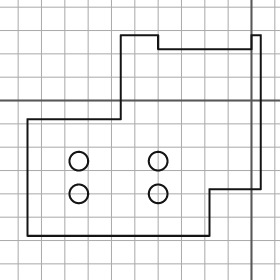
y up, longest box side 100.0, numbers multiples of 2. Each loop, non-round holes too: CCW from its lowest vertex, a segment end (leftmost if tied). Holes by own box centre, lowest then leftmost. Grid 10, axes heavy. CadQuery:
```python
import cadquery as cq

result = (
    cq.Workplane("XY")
    .moveTo(-96.0, -58.0)
    .lineTo(-18.0, -58.0)
    .lineTo(-18.0, -38.0)
    .lineTo(4.0, -38.0)
    .lineTo(4.0, 28.0)
    .lineTo(0.0, 28.0)
    .lineTo(0.0, 22.0)
    .lineTo(-40.0, 22.0)
    .lineTo(-40.0, 28.0)
    .lineTo(-56.0, 28.0)
    .lineTo(-56.0, -8.0)
    .lineTo(-96.0, -8.0)
    .close()
    .moveTo(-74.0, -40.0)
    .circle(4.0)
    .moveTo(-40.0, -40.0)
    .circle(4.0)
    .moveTo(-74.0, -26.0)
    .circle(4.0)
    .moveTo(-40.0, -26.0)
    .circle(4.0)
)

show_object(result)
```